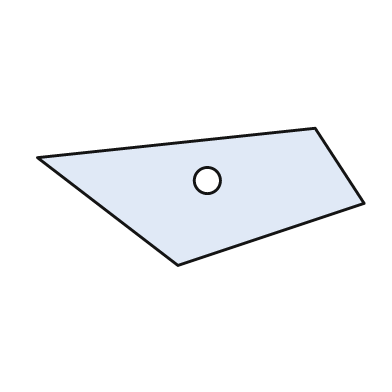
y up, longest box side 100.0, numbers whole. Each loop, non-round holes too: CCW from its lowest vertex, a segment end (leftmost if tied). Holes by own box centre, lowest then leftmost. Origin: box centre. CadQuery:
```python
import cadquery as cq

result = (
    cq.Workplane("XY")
    .moveTo(-7.0, -21.0)
    .lineTo(50.0, -2.0)
    .lineTo(35.0, 21.0)
    .lineTo(-50.0, 12.0)
    .close()
    .moveTo(2.0, 5.0)
    .circle(4.0)
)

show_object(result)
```